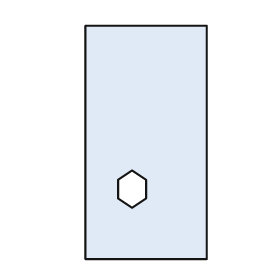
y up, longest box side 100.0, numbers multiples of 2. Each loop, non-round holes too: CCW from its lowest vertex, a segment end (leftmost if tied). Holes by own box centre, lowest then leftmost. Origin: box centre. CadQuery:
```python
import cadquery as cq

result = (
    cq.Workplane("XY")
    .moveTo(-26.0, -50.0)
    .lineTo(26.0, -50.0)
    .lineTo(26.0, 50.0)
    .lineTo(-26.0, 50.0)
    .close()
    .moveTo(-6.0, -28.0)
    .lineTo(0.0, -24.0)
    .lineTo(0.0, -16.0)
    .lineTo(-6.0, -12.0)
    .lineTo(-12.0, -16.0)
    .lineTo(-12.0, -24.0)
    .close()
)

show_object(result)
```